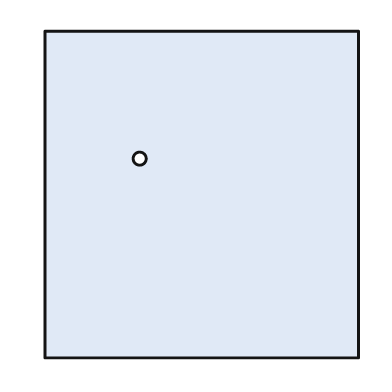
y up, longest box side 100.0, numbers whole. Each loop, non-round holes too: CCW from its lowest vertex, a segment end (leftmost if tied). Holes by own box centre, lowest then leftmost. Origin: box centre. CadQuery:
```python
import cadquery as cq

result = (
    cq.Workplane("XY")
    .moveTo(-48.0, -50.0)
    .lineTo(48.0, -50.0)
    .lineTo(48.0, 50.0)
    .lineTo(-48.0, 50.0)
    .close()
    .moveTo(-19.0, 11.0)
    .circle(2.0)
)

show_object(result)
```